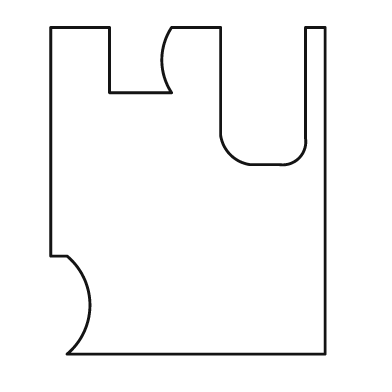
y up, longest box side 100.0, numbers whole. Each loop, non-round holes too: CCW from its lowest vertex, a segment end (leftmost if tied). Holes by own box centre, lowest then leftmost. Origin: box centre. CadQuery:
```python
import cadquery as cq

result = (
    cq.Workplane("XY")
    .moveTo(-37.0, -50.0)
    .lineTo(42.0, -50.0)
    .lineTo(42.0, 50.0)
    .lineTo(36.0, 50.0)
    .lineTo(36.0, 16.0)
    .threePointArc((34.0, 10.0), (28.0, 8.0))
    .lineTo(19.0, 8.0)
    .threePointArc((13.0, 11.0), (10.0, 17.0))
    .lineTo(10.0, 50.0)
    .lineTo(-5.0, 50.0)
    .threePointArc((-8.0, 40.0), (-5.0, 30.0))
    .lineTo(-24.0, 30.0)
    .lineTo(-24.0, 50.0)
    .lineTo(-42.0, 50.0)
    .lineTo(-42.0, -20.0)
    .lineTo(-37.0, -20.0)
    .threePointArc((-30.0, -35.0), (-37.0, -50.0))
    .close()
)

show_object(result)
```